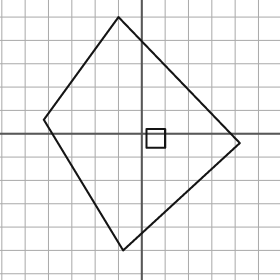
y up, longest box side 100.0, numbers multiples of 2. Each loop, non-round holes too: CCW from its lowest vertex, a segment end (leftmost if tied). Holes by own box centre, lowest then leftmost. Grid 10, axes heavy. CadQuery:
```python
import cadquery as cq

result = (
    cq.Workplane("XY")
    .moveTo(-8.0, -50.0)
    .lineTo(42.0, -4.0)
    .lineTo(-10.0, 50.0)
    .lineTo(-42.0, 6.0)
    .close()
    .moveTo(2.0, -6.0)
    .lineTo(10.0, -6.0)
    .lineTo(10.0, 2.0)
    .lineTo(2.0, 2.0)
    .close()
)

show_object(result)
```